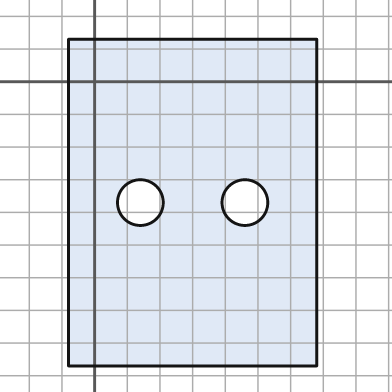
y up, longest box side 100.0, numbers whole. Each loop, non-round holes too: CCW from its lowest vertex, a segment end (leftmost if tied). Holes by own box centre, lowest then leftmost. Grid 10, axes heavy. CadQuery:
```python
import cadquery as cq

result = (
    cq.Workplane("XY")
    .moveTo(-8.0, -87.0)
    .lineTo(68.0, -87.0)
    .lineTo(68.0, 13.0)
    .lineTo(-8.0, 13.0)
    .close()
    .moveTo(14.0, -37.0)
    .circle(7.0)
    .moveTo(46.0, -37.0)
    .circle(7.0)
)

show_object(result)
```